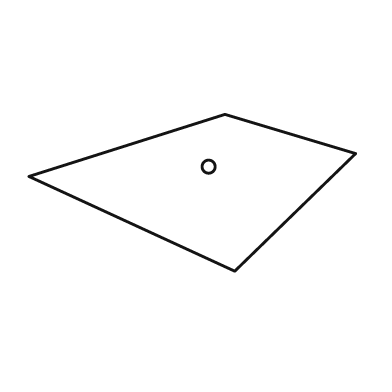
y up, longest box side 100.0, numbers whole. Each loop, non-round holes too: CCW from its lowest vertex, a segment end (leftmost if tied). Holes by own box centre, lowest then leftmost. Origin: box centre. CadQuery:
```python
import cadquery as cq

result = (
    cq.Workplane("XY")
    .moveTo(13.0, -24.0)
    .lineTo(50.0, 12.0)
    .lineTo(10.0, 24.0)
    .lineTo(-50.0, 5.0)
    .close()
    .moveTo(5.0, 8.0)
    .circle(2.0)
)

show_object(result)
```